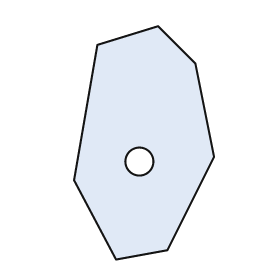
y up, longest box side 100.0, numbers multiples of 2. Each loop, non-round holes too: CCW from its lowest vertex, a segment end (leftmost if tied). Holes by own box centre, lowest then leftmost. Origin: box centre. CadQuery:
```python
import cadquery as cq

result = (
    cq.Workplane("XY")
    .moveTo(-12.0, -50.0)
    .lineTo(10.0, -46.0)
    .lineTo(30.0, -6.0)
    .lineTo(22.0, 34.0)
    .lineTo(6.0, 50.0)
    .lineTo(-20.0, 42.0)
    .lineTo(-30.0, -16.0)
    .close()
    .moveTo(-2.0, -8.0)
    .circle(6.0)
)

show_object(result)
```